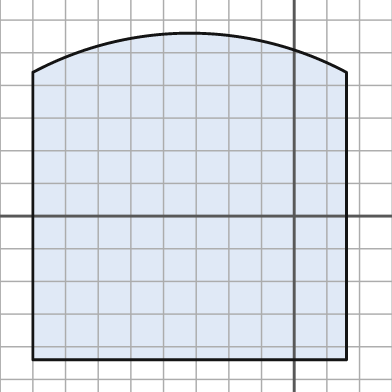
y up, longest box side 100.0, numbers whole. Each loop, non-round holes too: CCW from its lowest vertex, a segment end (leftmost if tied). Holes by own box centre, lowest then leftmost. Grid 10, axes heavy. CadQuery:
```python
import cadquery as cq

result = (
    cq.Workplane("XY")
    .moveTo(-80.0, -44.0)
    .lineTo(16.0, -44.0)
    .lineTo(16.0, 44.0)
    .threePointArc((-32.0, 56.0), (-80.0, 44.0))
    .close()
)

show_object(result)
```